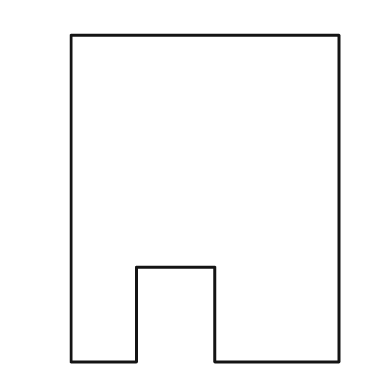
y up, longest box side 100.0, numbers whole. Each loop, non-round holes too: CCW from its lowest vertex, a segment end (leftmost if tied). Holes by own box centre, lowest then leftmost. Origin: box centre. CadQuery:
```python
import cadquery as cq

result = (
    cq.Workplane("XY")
    .moveTo(-41.0, -50.0)
    .lineTo(-21.0, -50.0)
    .lineTo(-21.0, -21.0)
    .lineTo(3.0, -21.0)
    .lineTo(3.0, -50.0)
    .lineTo(41.0, -50.0)
    .lineTo(41.0, 50.0)
    .lineTo(-41.0, 50.0)
    .close()
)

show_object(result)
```